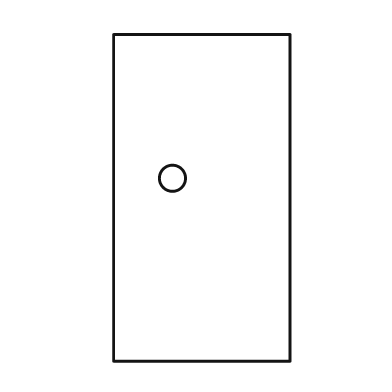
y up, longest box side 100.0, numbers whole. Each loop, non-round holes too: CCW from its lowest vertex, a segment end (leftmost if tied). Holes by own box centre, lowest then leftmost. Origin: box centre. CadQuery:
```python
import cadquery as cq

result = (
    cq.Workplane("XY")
    .moveTo(-27.0, -50.0)
    .lineTo(27.0, -50.0)
    .lineTo(27.0, 50.0)
    .lineTo(-27.0, 50.0)
    .close()
    .moveTo(-9.0, 6.0)
    .circle(4.0)
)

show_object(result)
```